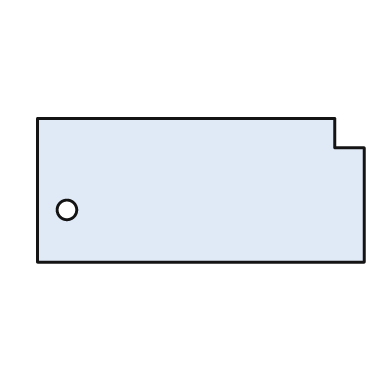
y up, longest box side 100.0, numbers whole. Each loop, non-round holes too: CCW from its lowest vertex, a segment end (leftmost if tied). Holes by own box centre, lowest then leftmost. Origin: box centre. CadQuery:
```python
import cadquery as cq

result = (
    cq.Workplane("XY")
    .moveTo(-50.0, -22.0)
    .lineTo(50.0, -22.0)
    .lineTo(50.0, 13.0)
    .lineTo(41.0, 13.0)
    .lineTo(41.0, 22.0)
    .lineTo(-50.0, 22.0)
    .close()
    .moveTo(-41.0, -6.0)
    .circle(3.0)
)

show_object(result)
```